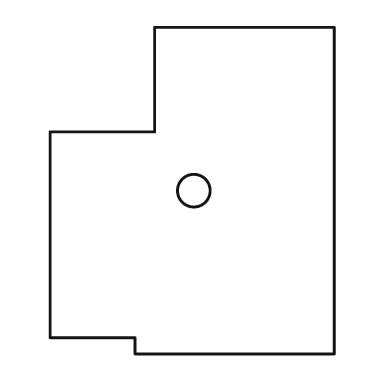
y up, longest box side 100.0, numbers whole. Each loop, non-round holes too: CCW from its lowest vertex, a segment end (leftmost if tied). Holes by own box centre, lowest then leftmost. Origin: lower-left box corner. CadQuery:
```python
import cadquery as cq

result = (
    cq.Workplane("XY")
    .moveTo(26.0, 0.0)
    .lineTo(87.0, 0.0)
    .lineTo(87.0, 100.0)
    .lineTo(32.0, 100.0)
    .lineTo(32.0, 68.0)
    .lineTo(0.0, 68.0)
    .lineTo(0.0, 5.0)
    .lineTo(26.0, 5.0)
    .close()
    .moveTo(44.0, 50.0)
    .circle(5.0)
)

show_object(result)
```